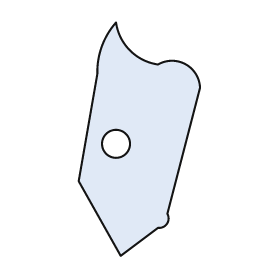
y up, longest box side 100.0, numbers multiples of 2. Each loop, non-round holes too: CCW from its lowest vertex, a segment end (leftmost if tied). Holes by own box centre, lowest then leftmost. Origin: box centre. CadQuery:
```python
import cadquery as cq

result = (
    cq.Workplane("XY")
    .moveTo(-8.0, -50.0)
    .lineTo(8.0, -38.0)
    .threePointArc((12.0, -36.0), (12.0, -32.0))
    .lineTo(26.0, 22.0)
    .threePointArc((20.0, 32.0), (8.0, 32.0))
    .threePointArc((-4.0, 38.0), (-10.0, 50.0))
    .threePointArc((-16.0, 40.0), (-18.0, 28.0))
    .lineTo(-26.0, -18.0)
    .close()
    .moveTo(-10.0, -2.0)
    .circle(6.0)
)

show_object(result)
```